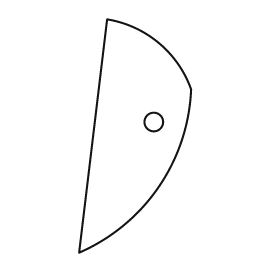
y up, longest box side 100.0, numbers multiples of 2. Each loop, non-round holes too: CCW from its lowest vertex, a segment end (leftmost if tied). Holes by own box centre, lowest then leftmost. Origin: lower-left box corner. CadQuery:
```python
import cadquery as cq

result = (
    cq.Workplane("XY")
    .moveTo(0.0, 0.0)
    .threePointArc((34.0, 28.0), (48.0, 70.0))
    .threePointArc((34.0, 90.0), (12.0, 100.0))
    .close()
    .moveTo(32.0, 56.0)
    .circle(4.0)
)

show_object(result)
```